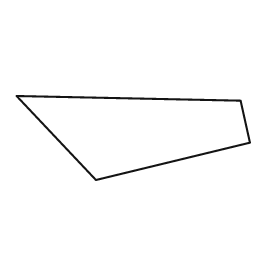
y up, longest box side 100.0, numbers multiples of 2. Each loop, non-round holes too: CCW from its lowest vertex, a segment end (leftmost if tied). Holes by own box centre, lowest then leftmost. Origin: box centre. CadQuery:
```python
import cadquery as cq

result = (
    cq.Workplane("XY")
    .moveTo(-16.0, -18.0)
    .lineTo(50.0, -2.0)
    .lineTo(46.0, 16.0)
    .lineTo(-50.0, 18.0)
    .close()
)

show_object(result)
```